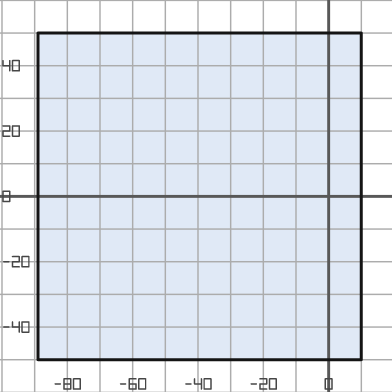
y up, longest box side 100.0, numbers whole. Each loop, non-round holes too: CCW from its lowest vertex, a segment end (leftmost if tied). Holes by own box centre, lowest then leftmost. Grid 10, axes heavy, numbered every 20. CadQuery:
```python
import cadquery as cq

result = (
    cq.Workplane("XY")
    .moveTo(-89.0, -50.0)
    .lineTo(10.0, -50.0)
    .lineTo(10.0, 50.0)
    .lineTo(-89.0, 50.0)
    .close()
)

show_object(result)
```